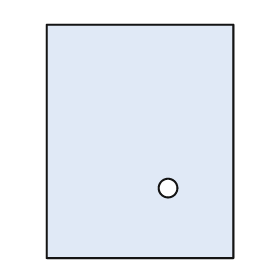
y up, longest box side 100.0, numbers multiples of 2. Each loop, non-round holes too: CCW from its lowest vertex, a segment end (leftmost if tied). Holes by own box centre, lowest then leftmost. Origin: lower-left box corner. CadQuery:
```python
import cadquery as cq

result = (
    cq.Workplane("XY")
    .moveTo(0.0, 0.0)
    .lineTo(80.0, 0.0)
    .lineTo(80.0, 100.0)
    .lineTo(0.0, 100.0)
    .close()
    .moveTo(52.0, 30.0)
    .circle(4.0)
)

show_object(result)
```